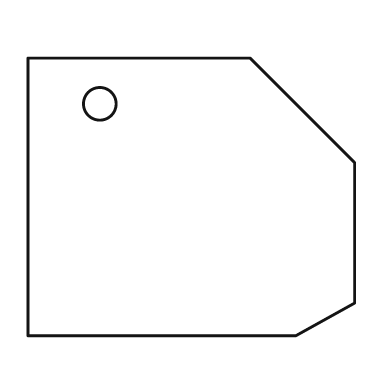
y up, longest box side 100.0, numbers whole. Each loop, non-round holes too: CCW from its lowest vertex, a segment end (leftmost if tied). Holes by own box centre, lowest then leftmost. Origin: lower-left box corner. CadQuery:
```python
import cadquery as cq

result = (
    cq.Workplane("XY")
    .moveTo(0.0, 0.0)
    .lineTo(82.0, 0.0)
    .lineTo(100.0, 10.0)
    .lineTo(100.0, 53.0)
    .lineTo(68.0, 85.0)
    .lineTo(0.0, 85.0)
    .close()
    .moveTo(22.0, 71.0)
    .circle(5.0)
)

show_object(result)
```